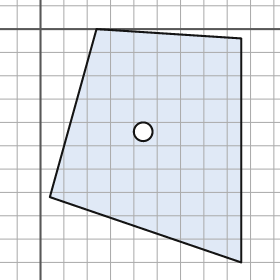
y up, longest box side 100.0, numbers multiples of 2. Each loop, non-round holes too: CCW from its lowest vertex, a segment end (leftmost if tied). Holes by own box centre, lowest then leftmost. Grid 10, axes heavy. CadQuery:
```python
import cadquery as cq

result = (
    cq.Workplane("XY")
    .moveTo(86.0, -100.0)
    .lineTo(86.0, -4.0)
    .lineTo(24.0, 0.0)
    .lineTo(4.0, -72.0)
    .close()
    .moveTo(44.0, -44.0)
    .circle(4.0)
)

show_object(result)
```